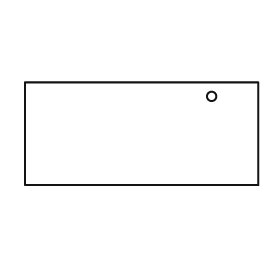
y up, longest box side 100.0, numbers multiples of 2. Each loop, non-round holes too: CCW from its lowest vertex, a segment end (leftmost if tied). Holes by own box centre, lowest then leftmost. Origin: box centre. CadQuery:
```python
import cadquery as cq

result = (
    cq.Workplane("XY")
    .moveTo(-50.0, -22.0)
    .lineTo(50.0, -22.0)
    .lineTo(50.0, 22.0)
    .lineTo(-50.0, 22.0)
    .close()
    .moveTo(30.0, 16.0)
    .circle(2.0)
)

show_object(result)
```